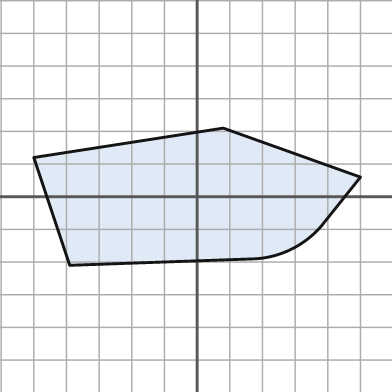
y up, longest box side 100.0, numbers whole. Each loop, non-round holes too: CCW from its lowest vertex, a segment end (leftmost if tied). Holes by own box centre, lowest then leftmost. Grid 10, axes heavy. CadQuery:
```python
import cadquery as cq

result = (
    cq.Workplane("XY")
    .moveTo(-39.0, -21.0)
    .lineTo(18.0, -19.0)
    .threePointArc((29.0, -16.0), (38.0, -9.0))
    .lineTo(50.0, 6.0)
    .lineTo(8.0, 21.0)
    .lineTo(-50.0, 12.0)
    .close()
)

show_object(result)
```